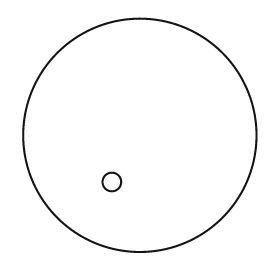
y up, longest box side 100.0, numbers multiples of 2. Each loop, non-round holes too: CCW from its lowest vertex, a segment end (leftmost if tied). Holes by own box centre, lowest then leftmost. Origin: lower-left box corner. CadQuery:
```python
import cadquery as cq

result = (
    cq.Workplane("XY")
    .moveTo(50.0, 50.0)
    .circle(50.0)
    .moveTo(38.0, 30.0)
    .circle(4.0)
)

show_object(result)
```